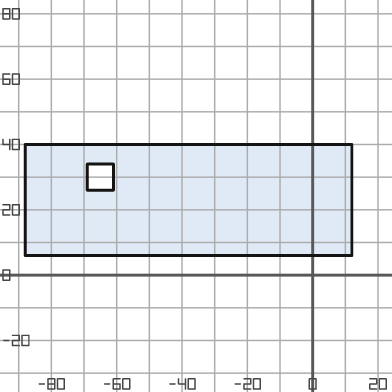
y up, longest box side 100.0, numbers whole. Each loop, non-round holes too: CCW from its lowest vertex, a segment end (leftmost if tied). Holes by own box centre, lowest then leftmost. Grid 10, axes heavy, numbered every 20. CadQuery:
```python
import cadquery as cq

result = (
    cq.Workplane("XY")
    .moveTo(-88.0, 6.0)
    .lineTo(12.0, 6.0)
    .lineTo(12.0, 40.0)
    .lineTo(-88.0, 40.0)
    .close()
    .moveTo(-69.0, 26.0)
    .lineTo(-61.0, 26.0)
    .lineTo(-61.0, 34.0)
    .lineTo(-69.0, 34.0)
    .close()
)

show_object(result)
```